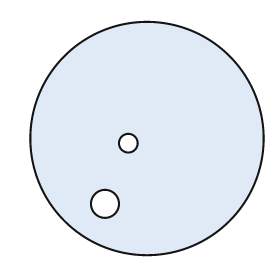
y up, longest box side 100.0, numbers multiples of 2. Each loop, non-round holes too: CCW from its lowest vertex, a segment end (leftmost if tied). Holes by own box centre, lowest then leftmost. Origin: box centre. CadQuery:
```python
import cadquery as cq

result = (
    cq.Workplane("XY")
    .moveTo(0.0, 0.0)
    .circle(50.0)
    .moveTo(-18.0, -28.0)
    .circle(6.0)
    .moveTo(-8.0, -2.0)
    .circle(4.0)
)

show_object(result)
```